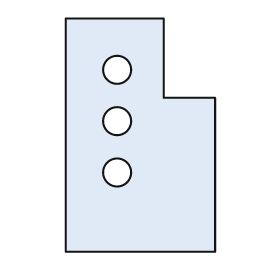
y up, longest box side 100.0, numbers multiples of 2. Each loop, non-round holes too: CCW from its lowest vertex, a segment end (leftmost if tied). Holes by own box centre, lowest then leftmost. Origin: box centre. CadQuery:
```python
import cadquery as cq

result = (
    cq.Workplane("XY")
    .moveTo(-32.0, -50.0)
    .lineTo(32.0, -50.0)
    .lineTo(32.0, 16.0)
    .lineTo(10.0, 16.0)
    .lineTo(10.0, 50.0)
    .lineTo(-32.0, 50.0)
    .close()
    .moveTo(-10.0, -16.0)
    .circle(6.0)
    .moveTo(-10.0, 6.0)
    .circle(6.0)
    .moveTo(-10.0, 28.0)
    .circle(6.0)
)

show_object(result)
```